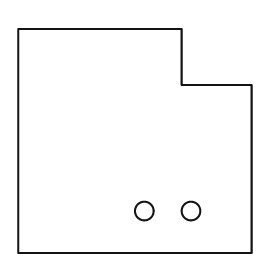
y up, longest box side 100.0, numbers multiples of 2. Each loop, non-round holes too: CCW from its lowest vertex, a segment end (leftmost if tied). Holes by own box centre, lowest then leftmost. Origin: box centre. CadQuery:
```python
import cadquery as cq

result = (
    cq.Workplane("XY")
    .moveTo(-50.0, -48.0)
    .lineTo(50.0, -48.0)
    .lineTo(50.0, 24.0)
    .lineTo(20.0, 24.0)
    .lineTo(20.0, 48.0)
    .lineTo(-50.0, 48.0)
    .close()
    .moveTo(4.0, -30.0)
    .circle(4.0)
    .moveTo(24.0, -30.0)
    .circle(4.0)
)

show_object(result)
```